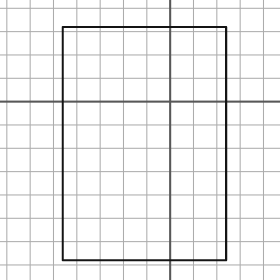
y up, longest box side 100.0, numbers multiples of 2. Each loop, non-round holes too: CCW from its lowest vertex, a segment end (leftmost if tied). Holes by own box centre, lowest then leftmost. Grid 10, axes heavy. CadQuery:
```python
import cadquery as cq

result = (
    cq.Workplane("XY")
    .moveTo(-46.0, -68.0)
    .lineTo(24.0, -68.0)
    .lineTo(24.0, 32.0)
    .lineTo(-46.0, 32.0)
    .close()
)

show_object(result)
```